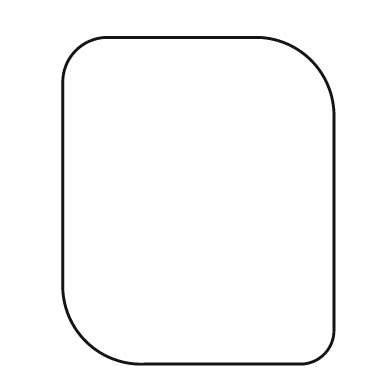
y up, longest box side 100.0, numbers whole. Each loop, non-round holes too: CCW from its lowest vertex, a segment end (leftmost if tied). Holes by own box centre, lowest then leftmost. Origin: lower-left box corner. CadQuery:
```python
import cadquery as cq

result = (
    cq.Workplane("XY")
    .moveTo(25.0, 0.0)
    .lineTo(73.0, 0.0)
    .threePointArc((80.0, 3.0), (83.0, 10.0))
    .lineTo(83.0, 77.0)
    .threePointArc((76.0, 93.0), (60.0, 100.0))
    .lineTo(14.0, 100.0)
    .threePointArc((4.0, 96.0), (0.0, 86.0))
    .lineTo(0.0, 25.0)
    .threePointArc((7.0, 7.0), (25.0, 0.0))
    .close()
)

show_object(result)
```